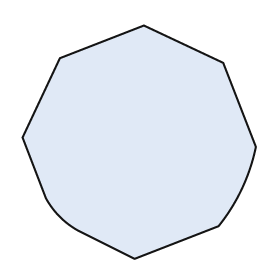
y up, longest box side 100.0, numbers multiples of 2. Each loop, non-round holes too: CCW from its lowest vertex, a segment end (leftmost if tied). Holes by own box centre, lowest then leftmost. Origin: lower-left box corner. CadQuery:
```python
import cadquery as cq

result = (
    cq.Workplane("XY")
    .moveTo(48.0, 0.0)
    .lineTo(84.0, 14.0)
    .threePointArc((94.0, 30.0), (100.0, 48.0))
    .lineTo(86.0, 84.0)
    .lineTo(52.0, 100.0)
    .lineTo(16.0, 86.0)
    .lineTo(0.0, 52.0)
    .lineTo(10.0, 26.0)
    .threePointArc((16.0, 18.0), (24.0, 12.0))
    .close()
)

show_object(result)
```